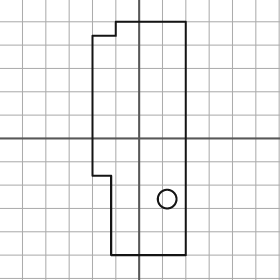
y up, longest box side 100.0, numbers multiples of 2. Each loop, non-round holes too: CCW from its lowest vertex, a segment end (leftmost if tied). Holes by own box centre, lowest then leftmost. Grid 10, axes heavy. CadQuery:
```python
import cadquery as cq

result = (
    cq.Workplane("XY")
    .moveTo(-12.0, -50.0)
    .lineTo(20.0, -50.0)
    .lineTo(20.0, 50.0)
    .lineTo(-10.0, 50.0)
    .lineTo(-10.0, 44.0)
    .lineTo(-20.0, 44.0)
    .lineTo(-20.0, -16.0)
    .lineTo(-12.0, -16.0)
    .close()
    .moveTo(12.0, -26.0)
    .circle(4.0)
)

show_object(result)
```